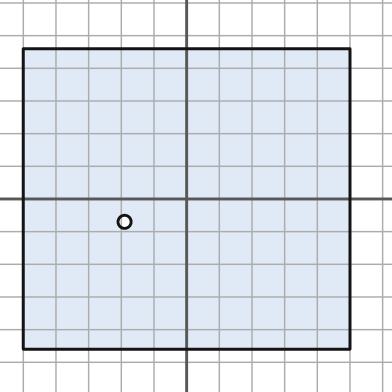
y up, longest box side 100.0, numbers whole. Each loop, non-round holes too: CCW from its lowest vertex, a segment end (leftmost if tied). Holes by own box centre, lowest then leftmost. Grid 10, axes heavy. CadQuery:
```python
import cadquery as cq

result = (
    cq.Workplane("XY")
    .moveTo(-50.0, -46.0)
    .lineTo(50.0, -46.0)
    .lineTo(50.0, 46.0)
    .lineTo(-50.0, 46.0)
    .close()
    .moveTo(-19.0, -7.0)
    .circle(2.0)
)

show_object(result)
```